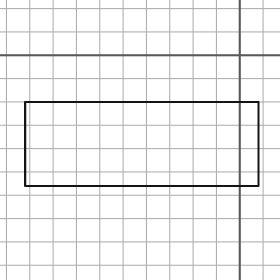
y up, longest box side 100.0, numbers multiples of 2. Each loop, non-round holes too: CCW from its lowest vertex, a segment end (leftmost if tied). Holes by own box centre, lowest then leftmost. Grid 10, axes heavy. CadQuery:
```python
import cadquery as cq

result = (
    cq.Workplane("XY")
    .moveTo(-92.0, -56.0)
    .lineTo(8.0, -56.0)
    .lineTo(8.0, -20.0)
    .lineTo(-92.0, -20.0)
    .close()
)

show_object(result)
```